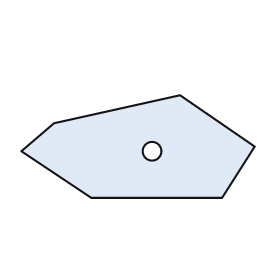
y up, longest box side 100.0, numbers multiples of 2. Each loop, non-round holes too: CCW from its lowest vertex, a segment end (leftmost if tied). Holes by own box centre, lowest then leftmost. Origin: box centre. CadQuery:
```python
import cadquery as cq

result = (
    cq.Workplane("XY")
    .moveTo(-20.0, -22.0)
    .lineTo(36.0, -22.0)
    .lineTo(50.0, 0.0)
    .lineTo(18.0, 22.0)
    .lineTo(-36.0, 10.0)
    .lineTo(-50.0, -2.0)
    .close()
    .moveTo(6.0, -2.0)
    .circle(4.0)
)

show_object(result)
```